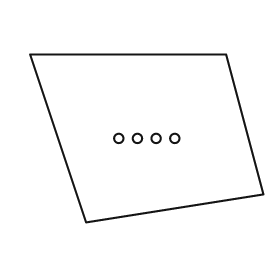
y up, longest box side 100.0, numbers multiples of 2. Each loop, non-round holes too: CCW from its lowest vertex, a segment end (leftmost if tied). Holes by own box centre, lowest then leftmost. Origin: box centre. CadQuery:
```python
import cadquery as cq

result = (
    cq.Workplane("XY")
    .moveTo(-26.0, -36.0)
    .lineTo(50.0, -24.0)
    .lineTo(34.0, 36.0)
    .lineTo(-50.0, 36.0)
    .close()
    .moveTo(-12.0, 0.0)
    .circle(2.0)
    .moveTo(-4.0, 0.0)
    .circle(2.0)
    .moveTo(4.0, 0.0)
    .circle(2.0)
    .moveTo(12.0, 0.0)
    .circle(2.0)
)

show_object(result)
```